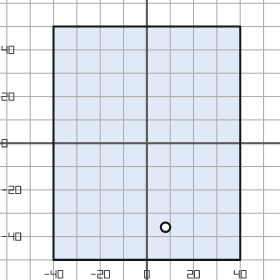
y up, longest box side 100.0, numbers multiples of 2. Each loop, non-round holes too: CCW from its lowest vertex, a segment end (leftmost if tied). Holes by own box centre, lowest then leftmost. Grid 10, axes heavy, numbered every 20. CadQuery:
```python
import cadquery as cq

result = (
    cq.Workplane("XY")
    .moveTo(-40.0, -50.0)
    .lineTo(40.0, -50.0)
    .lineTo(40.0, 50.0)
    .lineTo(-40.0, 50.0)
    .close()
    .moveTo(8.0, -36.0)
    .circle(2.0)
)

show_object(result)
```